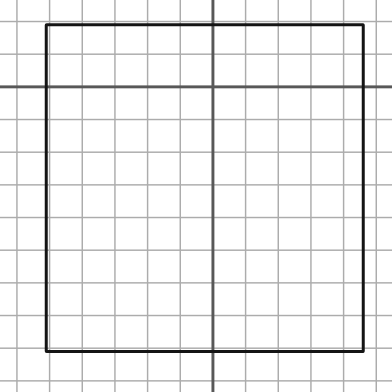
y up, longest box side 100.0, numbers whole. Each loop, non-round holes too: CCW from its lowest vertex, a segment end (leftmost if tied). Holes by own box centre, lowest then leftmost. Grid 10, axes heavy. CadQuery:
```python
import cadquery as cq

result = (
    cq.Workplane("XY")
    .moveTo(-51.0, -81.0)
    .lineTo(46.0, -81.0)
    .lineTo(46.0, 19.0)
    .lineTo(-51.0, 19.0)
    .close()
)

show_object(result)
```